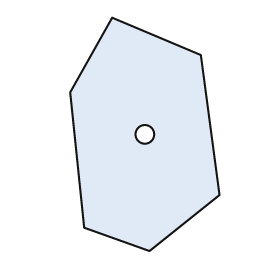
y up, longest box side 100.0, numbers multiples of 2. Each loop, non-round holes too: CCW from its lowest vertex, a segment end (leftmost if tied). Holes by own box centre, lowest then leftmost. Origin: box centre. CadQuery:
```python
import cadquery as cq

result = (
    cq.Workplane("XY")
    .moveTo(2.0, -50.0)
    .lineTo(32.0, -26.0)
    .lineTo(24.0, 34.0)
    .lineTo(-14.0, 50.0)
    .lineTo(-32.0, 18.0)
    .lineTo(-26.0, -40.0)
    .close()
    .moveTo(0.0, 0.0)
    .circle(4.0)
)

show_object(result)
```